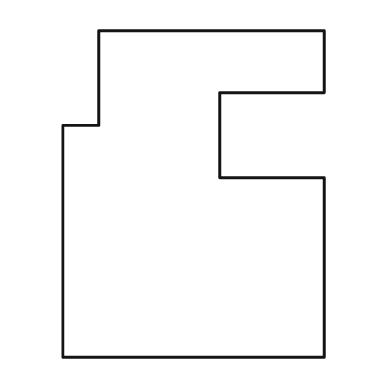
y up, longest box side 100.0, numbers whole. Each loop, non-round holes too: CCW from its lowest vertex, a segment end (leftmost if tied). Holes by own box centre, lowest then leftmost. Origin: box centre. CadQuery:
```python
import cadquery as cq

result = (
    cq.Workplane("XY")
    .moveTo(-40.0, -50.0)
    .lineTo(40.0, -50.0)
    .lineTo(40.0, 5.0)
    .lineTo(8.0, 5.0)
    .lineTo(8.0, 31.0)
    .lineTo(40.0, 31.0)
    .lineTo(40.0, 50.0)
    .lineTo(-29.0, 50.0)
    .lineTo(-29.0, 21.0)
    .lineTo(-40.0, 21.0)
    .close()
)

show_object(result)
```